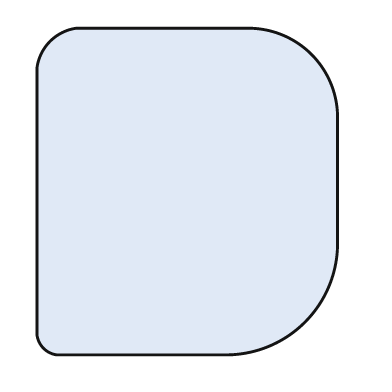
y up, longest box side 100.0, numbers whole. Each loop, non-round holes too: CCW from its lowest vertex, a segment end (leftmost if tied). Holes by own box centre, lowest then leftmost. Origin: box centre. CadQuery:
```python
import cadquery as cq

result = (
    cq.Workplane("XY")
    .moveTo(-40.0, -50.0)
    .lineTo(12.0, -50.0)
    .threePointArc((36.0, -40.0), (46.0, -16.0))
    .lineTo(46.0, 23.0)
    .threePointArc((38.0, 42.0), (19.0, 50.0))
    .lineTo(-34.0, 50.0)
    .threePointArc((-42.0, 46.0), (-46.0, 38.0))
    .lineTo(-46.0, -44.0)
    .threePointArc((-44.0, -48.0), (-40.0, -50.0))
    .close()
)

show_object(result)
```